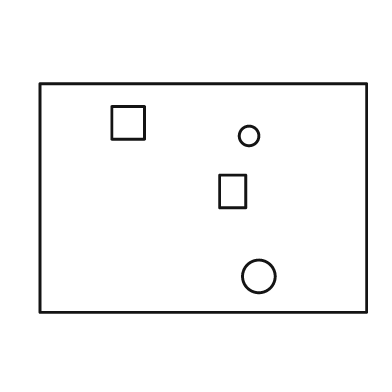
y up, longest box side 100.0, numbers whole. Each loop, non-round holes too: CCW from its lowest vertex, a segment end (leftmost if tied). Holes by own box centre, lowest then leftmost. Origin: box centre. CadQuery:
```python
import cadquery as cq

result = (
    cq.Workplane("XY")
    .moveTo(-50.0, -35.0)
    .lineTo(50.0, -35.0)
    .lineTo(50.0, 35.0)
    .lineTo(-50.0, 35.0)
    .close()
    .moveTo(17.0, -24.0)
    .circle(5.0)
    .moveTo(5.0, -3.0)
    .lineTo(13.0, -3.0)
    .lineTo(13.0, 7.0)
    .lineTo(5.0, 7.0)
    .close()
    .moveTo(14.0, 19.0)
    .circle(3.0)
    .moveTo(-28.0, 18.0)
    .lineTo(-18.0, 18.0)
    .lineTo(-18.0, 28.0)
    .lineTo(-28.0, 28.0)
    .close()
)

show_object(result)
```